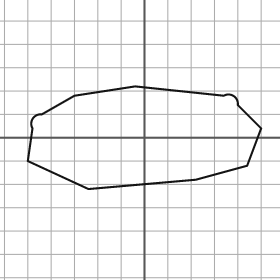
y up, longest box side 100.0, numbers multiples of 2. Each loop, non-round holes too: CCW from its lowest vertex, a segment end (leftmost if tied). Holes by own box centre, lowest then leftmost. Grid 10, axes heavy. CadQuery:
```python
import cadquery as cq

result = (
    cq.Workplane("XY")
    .moveTo(-24.0, -22.0)
    .lineTo(22.0, -18.0)
    .lineTo(44.0, -12.0)
    .lineTo(50.0, 4.0)
    .lineTo(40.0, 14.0)
    .threePointArc((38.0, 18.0), (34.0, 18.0))
    .lineTo(-4.0, 22.0)
    .lineTo(-30.0, 18.0)
    .lineTo(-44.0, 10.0)
    .threePointArc((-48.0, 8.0), (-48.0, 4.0))
    .lineTo(-50.0, -10.0)
    .close()
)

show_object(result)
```